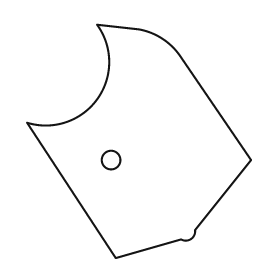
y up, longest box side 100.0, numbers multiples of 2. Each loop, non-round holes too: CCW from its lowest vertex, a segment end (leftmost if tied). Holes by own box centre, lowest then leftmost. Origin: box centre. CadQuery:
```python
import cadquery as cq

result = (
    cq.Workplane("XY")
    .moveTo(-10.0, -50.0)
    .lineTo(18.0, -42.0)
    .threePointArc((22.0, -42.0), (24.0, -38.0))
    .lineTo(48.0, -8.0)
    .lineTo(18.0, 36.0)
    .threePointArc((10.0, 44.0), (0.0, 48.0))
    .lineTo(-18.0, 50.0)
    .threePointArc((-18.0, 18.0), (-48.0, 8.0))
    .close()
    .moveTo(-12.0, -8.0)
    .circle(4.0)
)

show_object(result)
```